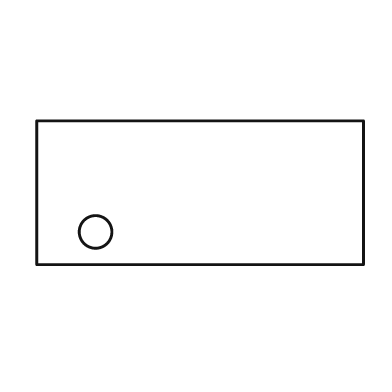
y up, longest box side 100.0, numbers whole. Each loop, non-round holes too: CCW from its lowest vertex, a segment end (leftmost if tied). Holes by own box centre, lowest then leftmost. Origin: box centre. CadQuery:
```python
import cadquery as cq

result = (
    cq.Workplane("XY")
    .moveTo(-50.0, -22.0)
    .lineTo(50.0, -22.0)
    .lineTo(50.0, 22.0)
    .lineTo(-50.0, 22.0)
    .close()
    .moveTo(-32.0, -12.0)
    .circle(5.0)
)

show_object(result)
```